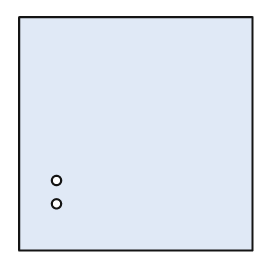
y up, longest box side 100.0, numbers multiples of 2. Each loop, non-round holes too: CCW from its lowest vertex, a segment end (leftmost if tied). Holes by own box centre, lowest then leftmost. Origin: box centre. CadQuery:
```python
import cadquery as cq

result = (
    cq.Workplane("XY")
    .moveTo(-50.0, -50.0)
    .lineTo(50.0, -50.0)
    .lineTo(50.0, 50.0)
    .lineTo(-50.0, 50.0)
    .close()
    .moveTo(-34.0, -30.0)
    .circle(2.0)
    .moveTo(-34.0, -20.0)
    .circle(2.0)
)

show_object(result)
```